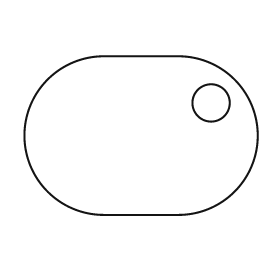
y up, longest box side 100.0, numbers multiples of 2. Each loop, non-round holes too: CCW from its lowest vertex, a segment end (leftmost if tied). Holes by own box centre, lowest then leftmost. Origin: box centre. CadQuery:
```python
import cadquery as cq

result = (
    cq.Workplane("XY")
    .moveTo(-16.0, -34.0)
    .lineTo(16.0, -34.0)
    .threePointArc((50.0, 0.0), (16.0, 34.0))
    .lineTo(-16.0, 34.0)
    .threePointArc((-50.0, 0.0), (-16.0, -34.0))
    .close()
    .moveTo(30.0, 14.0)
    .circle(8.0)
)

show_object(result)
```